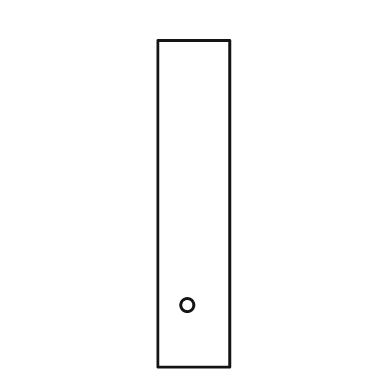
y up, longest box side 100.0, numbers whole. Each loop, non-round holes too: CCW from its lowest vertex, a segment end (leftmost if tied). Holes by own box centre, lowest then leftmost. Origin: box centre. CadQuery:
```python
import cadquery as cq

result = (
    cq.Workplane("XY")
    .moveTo(-11.0, -50.0)
    .lineTo(11.0, -50.0)
    .lineTo(11.0, 50.0)
    .lineTo(-11.0, 50.0)
    .close()
    .moveTo(-2.0, -31.0)
    .circle(2.0)
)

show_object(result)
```